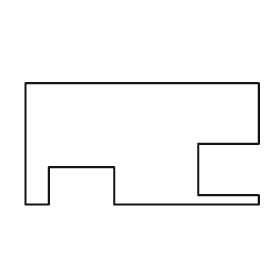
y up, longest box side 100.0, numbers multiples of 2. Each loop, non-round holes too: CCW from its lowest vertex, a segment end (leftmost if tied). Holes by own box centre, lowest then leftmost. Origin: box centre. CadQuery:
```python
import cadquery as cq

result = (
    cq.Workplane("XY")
    .moveTo(-50.0, -26.0)
    .lineTo(-40.0, -26.0)
    .lineTo(-40.0, -10.0)
    .lineTo(-12.0, -10.0)
    .lineTo(-12.0, -26.0)
    .lineTo(50.0, -26.0)
    .lineTo(50.0, -22.0)
    .lineTo(24.0, -22.0)
    .lineTo(24.0, 0.0)
    .lineTo(50.0, 0.0)
    .lineTo(50.0, 26.0)
    .lineTo(-50.0, 26.0)
    .close()
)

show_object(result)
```